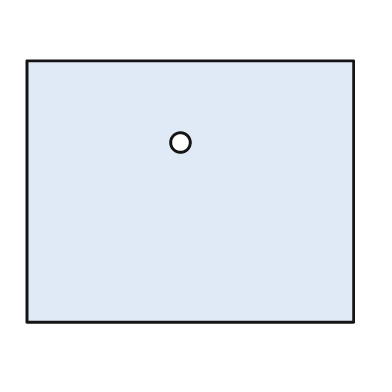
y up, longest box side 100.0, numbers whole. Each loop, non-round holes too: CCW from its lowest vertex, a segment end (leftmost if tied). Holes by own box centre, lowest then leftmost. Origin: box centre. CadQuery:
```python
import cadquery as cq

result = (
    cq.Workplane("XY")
    .moveTo(-50.0, -40.0)
    .lineTo(50.0, -40.0)
    .lineTo(50.0, 40.0)
    .lineTo(-50.0, 40.0)
    .close()
    .moveTo(-3.0, 15.0)
    .circle(3.0)
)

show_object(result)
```